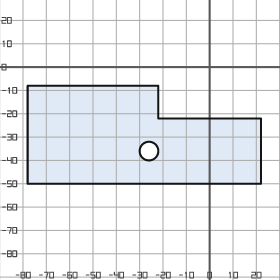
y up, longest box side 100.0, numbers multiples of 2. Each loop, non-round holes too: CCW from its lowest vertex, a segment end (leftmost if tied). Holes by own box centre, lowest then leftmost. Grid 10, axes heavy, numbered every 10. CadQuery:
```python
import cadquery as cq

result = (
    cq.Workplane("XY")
    .moveTo(-78.0, -50.0)
    .lineTo(22.0, -50.0)
    .lineTo(22.0, -22.0)
    .lineTo(-22.0, -22.0)
    .lineTo(-22.0, -8.0)
    .lineTo(-78.0, -8.0)
    .close()
    .moveTo(-26.0, -36.0)
    .circle(4.0)
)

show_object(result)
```